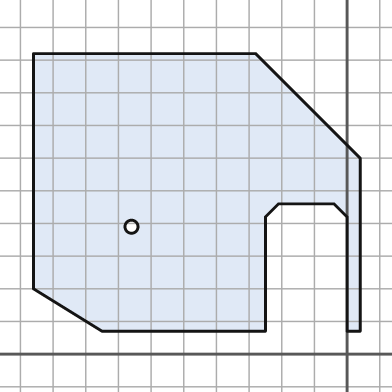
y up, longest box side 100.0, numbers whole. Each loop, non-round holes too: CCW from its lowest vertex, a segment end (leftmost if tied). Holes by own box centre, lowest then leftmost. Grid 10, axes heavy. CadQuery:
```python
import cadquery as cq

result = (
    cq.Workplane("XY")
    .moveTo(-75.0, 7.0)
    .lineTo(-25.0, 7.0)
    .lineTo(-25.0, 42.0)
    .lineTo(-21.0, 46.0)
    .lineTo(-4.0, 46.0)
    .lineTo(0.0, 42.0)
    .lineTo(0.0, 7.0)
    .lineTo(4.0, 7.0)
    .lineTo(4.0, 60.0)
    .lineTo(-28.0, 92.0)
    .lineTo(-96.0, 92.0)
    .lineTo(-96.0, 20.0)
    .close()
    .moveTo(-66.0, 39.0)
    .circle(2.0)
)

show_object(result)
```